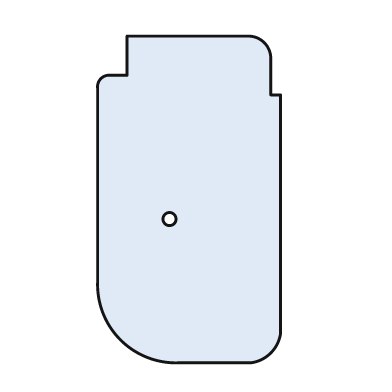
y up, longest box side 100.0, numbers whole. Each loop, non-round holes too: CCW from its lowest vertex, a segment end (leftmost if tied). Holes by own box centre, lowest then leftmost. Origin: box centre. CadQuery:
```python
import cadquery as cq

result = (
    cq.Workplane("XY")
    .moveTo(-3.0, -50.0)
    .lineTo(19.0, -50.0)
    .threePointArc((25.0, -47.0), (28.0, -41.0))
    .lineTo(28.0, 32.0)
    .lineTo(25.0, 32.0)
    .lineTo(25.0, 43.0)
    .threePointArc((23.0, 48.0), (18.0, 50.0))
    .lineTo(-19.0, 50.0)
    .lineTo(-19.0, 38.0)
    .lineTo(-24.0, 38.0)
    .threePointArc((-27.0, 37.0), (-28.0, 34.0))
    .lineTo(-28.0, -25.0)
    .threePointArc((-21.0, -43.0), (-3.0, -50.0))
    .close()
    .moveTo(-6.0, -6.0)
    .circle(2.0)
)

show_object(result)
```